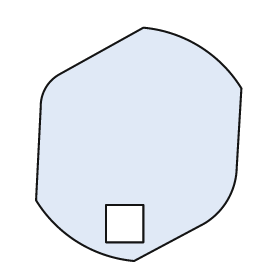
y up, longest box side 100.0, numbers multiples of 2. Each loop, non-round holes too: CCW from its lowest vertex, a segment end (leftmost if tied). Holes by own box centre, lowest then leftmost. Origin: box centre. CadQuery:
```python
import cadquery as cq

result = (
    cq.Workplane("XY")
    .moveTo(-2.0, -50.0)
    .lineTo(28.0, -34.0)
    .threePointArc((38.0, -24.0), (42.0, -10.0))
    .lineTo(44.0, 24.0)
    .threePointArc((26.0, 42.0), (2.0, 50.0))
    .lineTo(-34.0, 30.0)
    .threePointArc((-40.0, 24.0), (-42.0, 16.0))
    .lineTo(-44.0, -24.0)
    .threePointArc((-26.0, -42.0), (-2.0, -50.0))
    .close()
    .moveTo(-14.0, -42.0)
    .lineTo(2.0, -42.0)
    .lineTo(2.0, -26.0)
    .lineTo(-14.0, -26.0)
    .close()
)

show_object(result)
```